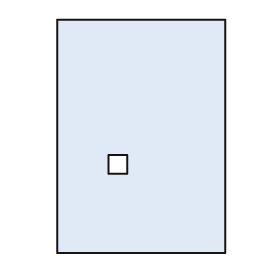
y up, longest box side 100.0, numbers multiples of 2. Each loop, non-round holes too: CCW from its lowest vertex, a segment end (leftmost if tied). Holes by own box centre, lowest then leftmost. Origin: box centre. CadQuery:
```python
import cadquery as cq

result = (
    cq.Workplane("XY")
    .moveTo(-36.0, -50.0)
    .lineTo(36.0, -50.0)
    .lineTo(36.0, 50.0)
    .lineTo(-36.0, 50.0)
    .close()
    .moveTo(-14.0, -16.0)
    .lineTo(-6.0, -16.0)
    .lineTo(-6.0, -8.0)
    .lineTo(-14.0, -8.0)
    .close()
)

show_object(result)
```